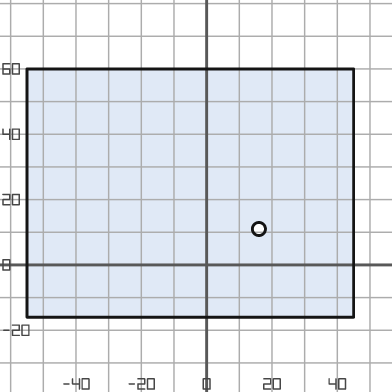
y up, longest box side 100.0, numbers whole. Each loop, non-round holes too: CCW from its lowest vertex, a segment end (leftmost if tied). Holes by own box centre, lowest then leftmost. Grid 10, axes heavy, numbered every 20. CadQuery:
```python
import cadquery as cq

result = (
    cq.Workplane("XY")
    .moveTo(-55.0, -16.0)
    .lineTo(45.0, -16.0)
    .lineTo(45.0, 60.0)
    .lineTo(-55.0, 60.0)
    .close()
    .moveTo(16.0, 11.0)
    .circle(2.0)
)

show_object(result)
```